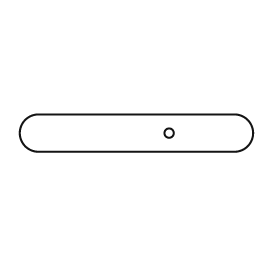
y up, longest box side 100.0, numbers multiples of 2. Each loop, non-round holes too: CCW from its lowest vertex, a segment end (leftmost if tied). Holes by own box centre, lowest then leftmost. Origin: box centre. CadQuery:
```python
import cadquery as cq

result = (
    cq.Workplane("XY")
    .moveTo(-42.0, -8.0)
    .lineTo(42.0, -8.0)
    .threePointArc((50.0, 0.0), (42.0, 8.0))
    .lineTo(-42.0, 8.0)
    .threePointArc((-50.0, 0.0), (-42.0, -8.0))
    .close()
    .moveTo(14.0, 0.0)
    .circle(2.0)
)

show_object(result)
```